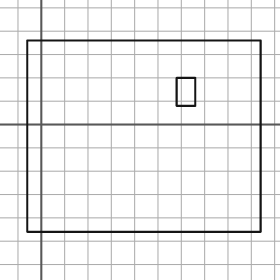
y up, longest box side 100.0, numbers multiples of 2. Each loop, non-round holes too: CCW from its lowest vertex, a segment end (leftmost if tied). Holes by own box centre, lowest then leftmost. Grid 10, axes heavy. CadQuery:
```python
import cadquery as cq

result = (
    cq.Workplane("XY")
    .moveTo(-6.0, -46.0)
    .lineTo(94.0, -46.0)
    .lineTo(94.0, 36.0)
    .lineTo(-6.0, 36.0)
    .close()
    .moveTo(58.0, 8.0)
    .lineTo(66.0, 8.0)
    .lineTo(66.0, 20.0)
    .lineTo(58.0, 20.0)
    .close()
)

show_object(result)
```